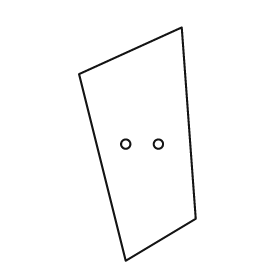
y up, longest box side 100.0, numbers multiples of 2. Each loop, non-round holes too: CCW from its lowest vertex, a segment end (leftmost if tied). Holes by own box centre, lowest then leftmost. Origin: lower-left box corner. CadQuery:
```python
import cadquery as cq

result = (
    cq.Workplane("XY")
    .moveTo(20.0, 0.0)
    .lineTo(50.0, 18.0)
    .lineTo(44.0, 100.0)
    .lineTo(0.0, 80.0)
    .close()
    .moveTo(20.0, 50.0)
    .circle(2.0)
    .moveTo(34.0, 50.0)
    .circle(2.0)
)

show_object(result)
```